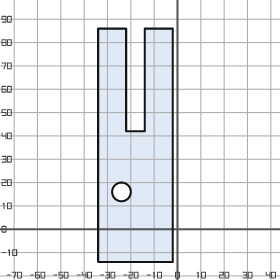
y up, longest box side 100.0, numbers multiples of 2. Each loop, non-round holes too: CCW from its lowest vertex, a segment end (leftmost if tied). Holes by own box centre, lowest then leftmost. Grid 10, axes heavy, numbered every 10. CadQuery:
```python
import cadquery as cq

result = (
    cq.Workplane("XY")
    .moveTo(-34.0, -14.0)
    .lineTo(-2.0, -14.0)
    .lineTo(-2.0, 86.0)
    .lineTo(-14.0, 86.0)
    .lineTo(-14.0, 42.0)
    .lineTo(-22.0, 42.0)
    .lineTo(-22.0, 86.0)
    .lineTo(-34.0, 86.0)
    .close()
    .moveTo(-24.0, 16.0)
    .circle(4.0)
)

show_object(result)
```